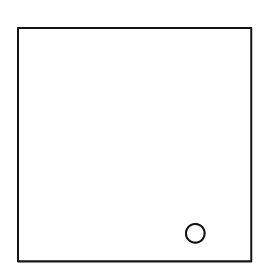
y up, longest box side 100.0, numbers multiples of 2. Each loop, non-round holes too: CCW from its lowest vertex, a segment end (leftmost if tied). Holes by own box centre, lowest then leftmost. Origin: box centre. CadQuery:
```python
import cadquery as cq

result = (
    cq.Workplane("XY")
    .moveTo(-50.0, -50.0)
    .lineTo(50.0, -50.0)
    .lineTo(50.0, 50.0)
    .lineTo(-50.0, 50.0)
    .close()
    .moveTo(26.0, -38.0)
    .circle(4.0)
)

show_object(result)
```